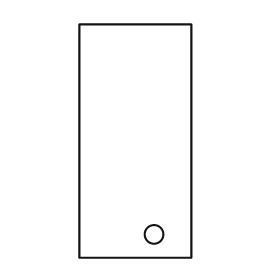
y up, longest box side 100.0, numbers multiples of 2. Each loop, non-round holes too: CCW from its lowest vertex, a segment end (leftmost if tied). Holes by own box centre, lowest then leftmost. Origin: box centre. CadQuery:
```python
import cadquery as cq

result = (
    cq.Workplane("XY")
    .moveTo(-24.0, -50.0)
    .lineTo(24.0, -50.0)
    .lineTo(24.0, 50.0)
    .lineTo(-24.0, 50.0)
    .close()
    .moveTo(8.0, -40.0)
    .circle(4.0)
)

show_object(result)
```